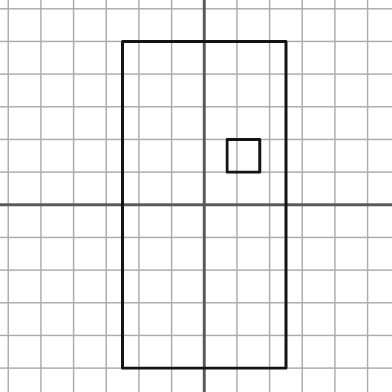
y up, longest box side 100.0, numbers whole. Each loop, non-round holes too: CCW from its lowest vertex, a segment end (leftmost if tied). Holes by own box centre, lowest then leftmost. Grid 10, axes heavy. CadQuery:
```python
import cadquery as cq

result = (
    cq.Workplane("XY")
    .moveTo(-25.0, -50.0)
    .lineTo(25.0, -50.0)
    .lineTo(25.0, 50.0)
    .lineTo(-25.0, 50.0)
    .close()
    .moveTo(7.0, 10.0)
    .lineTo(17.0, 10.0)
    .lineTo(17.0, 20.0)
    .lineTo(7.0, 20.0)
    .close()
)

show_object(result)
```